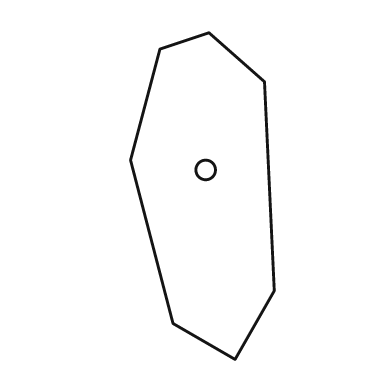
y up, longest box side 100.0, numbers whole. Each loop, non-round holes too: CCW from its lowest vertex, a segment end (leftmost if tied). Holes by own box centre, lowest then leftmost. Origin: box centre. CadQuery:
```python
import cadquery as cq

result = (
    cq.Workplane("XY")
    .moveTo(10.0, -50.0)
    .lineTo(22.0, -29.0)
    .lineTo(19.0, 35.0)
    .lineTo(2.0, 50.0)
    .lineTo(-13.0, 45.0)
    .lineTo(-22.0, 11.0)
    .lineTo(-9.0, -39.0)
    .close()
    .moveTo(1.0, 8.0)
    .circle(3.0)
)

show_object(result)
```